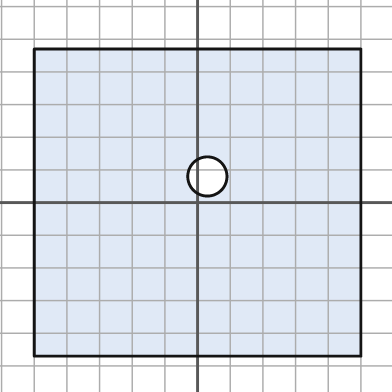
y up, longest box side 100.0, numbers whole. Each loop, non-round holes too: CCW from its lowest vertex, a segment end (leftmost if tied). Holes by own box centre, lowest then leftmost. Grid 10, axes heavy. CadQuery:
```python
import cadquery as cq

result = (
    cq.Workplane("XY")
    .moveTo(-50.0, -47.0)
    .lineTo(50.0, -47.0)
    .lineTo(50.0, 47.0)
    .lineTo(-50.0, 47.0)
    .close()
    .moveTo(3.0, 8.0)
    .circle(6.0)
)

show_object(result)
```